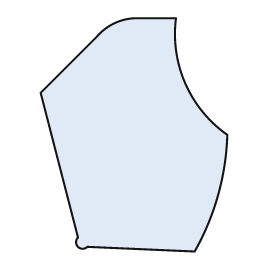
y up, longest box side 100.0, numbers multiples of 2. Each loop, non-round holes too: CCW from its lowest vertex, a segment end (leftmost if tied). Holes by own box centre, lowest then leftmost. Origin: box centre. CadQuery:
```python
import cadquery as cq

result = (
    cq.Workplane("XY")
    .moveTo(26.0, -50.0)
    .threePointArc((36.0, -26.0), (40.0, 0.0))
    .threePointArc((22.0, 22.0), (18.0, 50.0))
    .lineTo(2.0, 50.0)
    .threePointArc((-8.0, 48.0), (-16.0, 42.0))
    .lineTo(-40.0, 18.0)
    .lineTo(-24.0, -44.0)
    .threePointArc((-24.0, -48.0), (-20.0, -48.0))
    .close()
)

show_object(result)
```